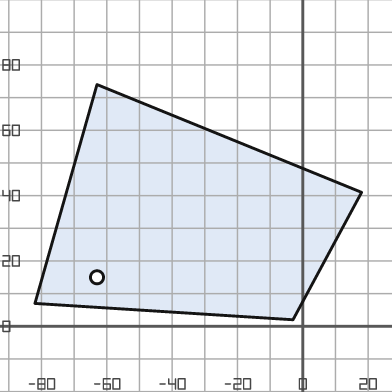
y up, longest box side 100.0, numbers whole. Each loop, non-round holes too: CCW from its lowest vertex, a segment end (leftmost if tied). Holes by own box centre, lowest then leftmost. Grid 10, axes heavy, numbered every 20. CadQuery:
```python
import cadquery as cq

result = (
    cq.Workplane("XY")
    .moveTo(-3.0, 2.0)
    .lineTo(18.0, 41.0)
    .lineTo(-63.0, 74.0)
    .lineTo(-82.0, 7.0)
    .close()
    .moveTo(-63.0, 15.0)
    .circle(2.0)
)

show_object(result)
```